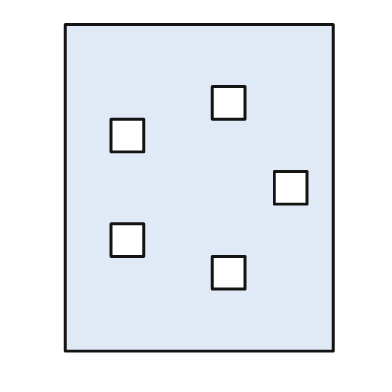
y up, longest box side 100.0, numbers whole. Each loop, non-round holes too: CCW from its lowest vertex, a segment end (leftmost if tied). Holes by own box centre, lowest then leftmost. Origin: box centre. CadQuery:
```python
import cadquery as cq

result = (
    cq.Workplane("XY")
    .moveTo(-41.0, -50.0)
    .lineTo(41.0, -50.0)
    .lineTo(41.0, 50.0)
    .lineTo(-41.0, 50.0)
    .close()
    .moveTo(4.0, -31.0)
    .lineTo(14.0, -31.0)
    .lineTo(14.0, -21.0)
    .lineTo(4.0, -21.0)
    .close()
    .moveTo(-27.0, -21.0)
    .lineTo(-17.0, -21.0)
    .lineTo(-17.0, -11.0)
    .lineTo(-27.0, -11.0)
    .close()
    .moveTo(23.0, -5.0)
    .lineTo(33.0, -5.0)
    .lineTo(33.0, 5.0)
    .lineTo(23.0, 5.0)
    .close()
    .moveTo(-27.0, 11.0)
    .lineTo(-17.0, 11.0)
    .lineTo(-17.0, 21.0)
    .lineTo(-27.0, 21.0)
    .close()
    .moveTo(4.0, 21.0)
    .lineTo(14.0, 21.0)
    .lineTo(14.0, 31.0)
    .lineTo(4.0, 31.0)
    .close()
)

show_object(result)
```